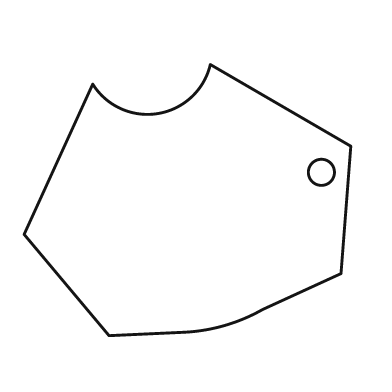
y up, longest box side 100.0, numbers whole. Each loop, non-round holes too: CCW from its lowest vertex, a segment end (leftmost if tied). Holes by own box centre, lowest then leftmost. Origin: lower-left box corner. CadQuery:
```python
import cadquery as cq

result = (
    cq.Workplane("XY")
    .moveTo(26.0, 0.0)
    .lineTo(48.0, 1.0)
    .threePointArc((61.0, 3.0), (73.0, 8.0))
    .lineTo(97.0, 19.0)
    .lineTo(100.0, 58.0)
    .lineTo(57.0, 83.0)
    .threePointArc((41.0, 68.0), (21.0, 77.0))
    .lineTo(0.0, 31.0)
    .close()
    .moveTo(91.0, 50.0)
    .circle(4.0)
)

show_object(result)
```